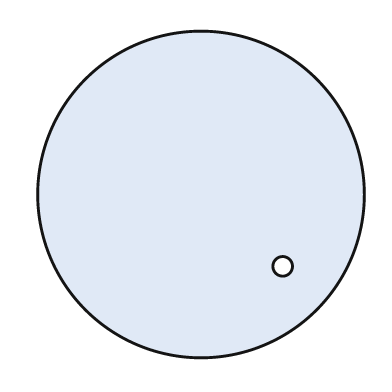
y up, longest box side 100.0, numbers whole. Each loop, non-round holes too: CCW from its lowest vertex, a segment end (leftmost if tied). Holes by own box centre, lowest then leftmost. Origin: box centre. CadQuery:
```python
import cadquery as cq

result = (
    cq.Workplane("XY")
    .moveTo(0.0, 0.0)
    .circle(50.0)
    .moveTo(25.0, -22.0)
    .circle(3.0)
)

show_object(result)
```